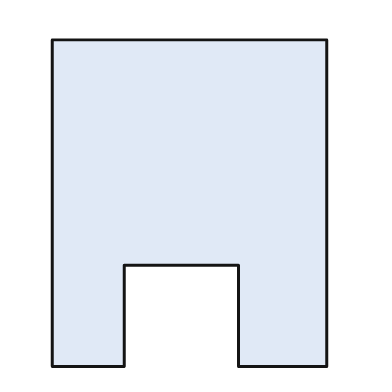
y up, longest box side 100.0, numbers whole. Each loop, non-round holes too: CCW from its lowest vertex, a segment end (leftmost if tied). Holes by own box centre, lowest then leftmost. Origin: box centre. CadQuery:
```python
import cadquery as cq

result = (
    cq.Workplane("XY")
    .moveTo(-42.0, -50.0)
    .lineTo(-20.0, -50.0)
    .lineTo(-20.0, -19.0)
    .lineTo(15.0, -19.0)
    .lineTo(15.0, -50.0)
    .lineTo(42.0, -50.0)
    .lineTo(42.0, 50.0)
    .lineTo(-42.0, 50.0)
    .close()
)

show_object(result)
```